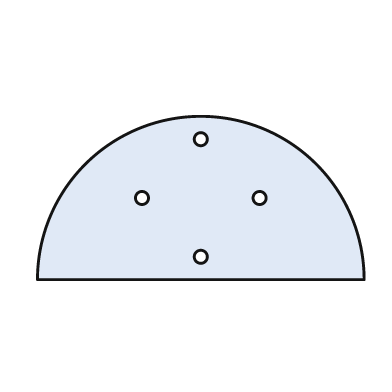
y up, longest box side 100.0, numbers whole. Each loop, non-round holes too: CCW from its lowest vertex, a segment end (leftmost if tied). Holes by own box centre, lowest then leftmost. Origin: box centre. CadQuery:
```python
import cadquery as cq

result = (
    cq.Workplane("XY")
    .moveTo(-50.0, -25.0)
    .lineTo(50.0, -25.0)
    .threePointArc((0.0, 25.0), (-50.0, -25.0))
    .close()
    .moveTo(0.0, -18.0)
    .circle(2.0)
    .moveTo(-18.0, 0.0)
    .circle(2.0)
    .moveTo(18.0, 0.0)
    .circle(2.0)
    .moveTo(0.0, 18.0)
    .circle(2.0)
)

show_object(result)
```